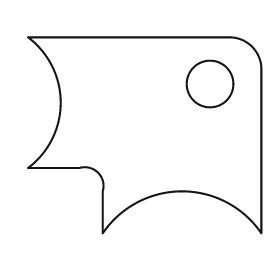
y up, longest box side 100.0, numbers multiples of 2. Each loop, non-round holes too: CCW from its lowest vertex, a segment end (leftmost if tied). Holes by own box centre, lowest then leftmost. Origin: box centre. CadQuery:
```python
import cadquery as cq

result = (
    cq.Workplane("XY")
    .moveTo(-18.0, -42.0)
    .threePointArc((16.0, -24.0), (50.0, -42.0))
    .lineTo(50.0, 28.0)
    .threePointArc((46.0, 38.0), (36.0, 42.0))
    .lineTo(-50.0, 42.0)
    .threePointArc((-36.0, 14.0), (-50.0, -14.0))
    .lineTo(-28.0, -14.0)
    .threePointArc((-20.0, -16.0), (-18.0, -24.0))
    .close()
    .moveTo(28.0, 22.0)
    .circle(10.0)
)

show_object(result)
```